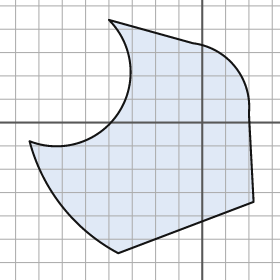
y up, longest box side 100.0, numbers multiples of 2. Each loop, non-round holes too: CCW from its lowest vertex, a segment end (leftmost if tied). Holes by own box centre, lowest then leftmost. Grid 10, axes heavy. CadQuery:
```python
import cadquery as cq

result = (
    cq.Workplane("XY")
    .moveTo(-36.0, -56.0)
    .lineTo(22.0, -34.0)
    .lineTo(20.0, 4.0)
    .threePointArc((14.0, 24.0), (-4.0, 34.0))
    .lineTo(-40.0, 44.0)
    .threePointArc((-36.0, 4.0), (-74.0, -8.0))
    .threePointArc((-60.0, -36.0), (-36.0, -56.0))
    .close()
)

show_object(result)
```